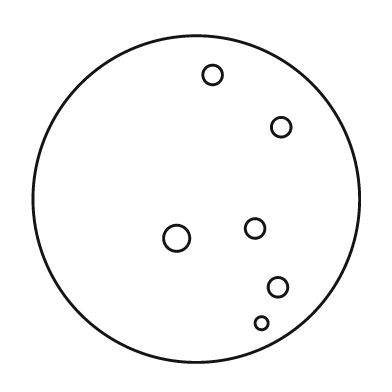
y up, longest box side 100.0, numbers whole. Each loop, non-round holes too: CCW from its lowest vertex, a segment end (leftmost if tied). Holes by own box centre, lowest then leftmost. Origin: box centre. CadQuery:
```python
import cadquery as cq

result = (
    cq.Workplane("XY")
    .moveTo(0.0, 0.0)
    .circle(50.0)
    .moveTo(20.0, -38.0)
    .circle(2.0)
    .moveTo(25.0, -27.0)
    .circle(3.0)
    .moveTo(-6.0, -12.0)
    .circle(4.0)
    .moveTo(18.0, -9.0)
    .circle(3.0)
    .moveTo(26.0, 22.0)
    .circle(3.0)
    .moveTo(5.0, 38.0)
    .circle(3.0)
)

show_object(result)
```